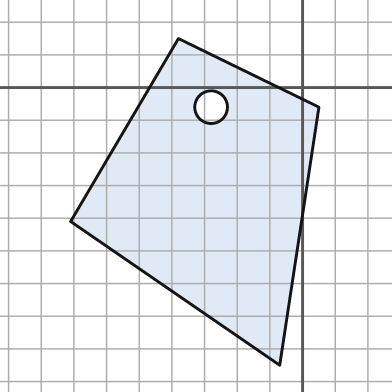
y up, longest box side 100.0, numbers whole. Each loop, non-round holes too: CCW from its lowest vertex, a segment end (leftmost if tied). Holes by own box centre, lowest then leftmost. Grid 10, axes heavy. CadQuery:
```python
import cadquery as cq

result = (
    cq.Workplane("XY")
    .moveTo(-7.0, -85.0)
    .lineTo(5.0, -6.0)
    .lineTo(-38.0, 15.0)
    .lineTo(-71.0, -41.0)
    .close()
    .moveTo(-28.0, -6.0)
    .circle(5.0)
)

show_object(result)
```